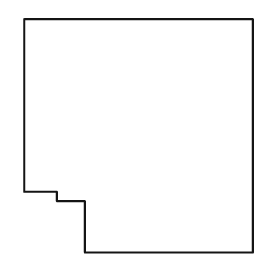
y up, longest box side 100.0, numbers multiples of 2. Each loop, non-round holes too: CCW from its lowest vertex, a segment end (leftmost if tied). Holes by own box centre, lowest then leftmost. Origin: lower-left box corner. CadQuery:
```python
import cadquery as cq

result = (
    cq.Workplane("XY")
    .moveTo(26.0, 0.0)
    .lineTo(98.0, 0.0)
    .lineTo(98.0, 100.0)
    .lineTo(0.0, 100.0)
    .lineTo(0.0, 26.0)
    .lineTo(14.0, 26.0)
    .lineTo(14.0, 22.0)
    .lineTo(26.0, 22.0)
    .close()
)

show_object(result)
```